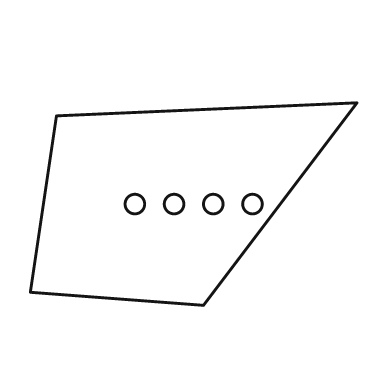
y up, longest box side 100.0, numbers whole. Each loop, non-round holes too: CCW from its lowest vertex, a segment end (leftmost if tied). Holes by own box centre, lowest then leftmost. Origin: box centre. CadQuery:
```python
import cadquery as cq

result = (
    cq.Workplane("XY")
    .moveTo(3.0, -31.0)
    .lineTo(50.0, 31.0)
    .lineTo(-42.0, 27.0)
    .lineTo(-50.0, -27.0)
    .close()
    .moveTo(-18.0, 0.0)
    .circle(3.0)
    .moveTo(-6.0, 0.0)
    .circle(3.0)
    .moveTo(6.0, 0.0)
    .circle(3.0)
    .moveTo(18.0, 0.0)
    .circle(3.0)
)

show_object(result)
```